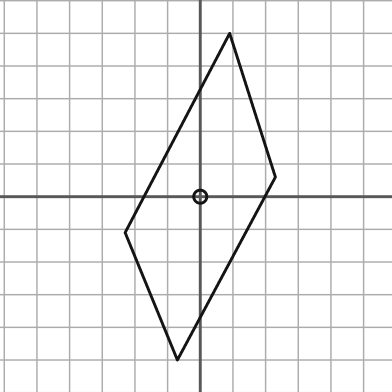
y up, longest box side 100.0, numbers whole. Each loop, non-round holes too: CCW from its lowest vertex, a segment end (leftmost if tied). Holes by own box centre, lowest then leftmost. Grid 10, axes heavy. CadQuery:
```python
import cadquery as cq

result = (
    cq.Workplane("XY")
    .moveTo(-7.0, -50.0)
    .lineTo(23.0, 6.0)
    .lineTo(9.0, 50.0)
    .lineTo(-23.0, -11.0)
    .close()
    .moveTo(0.0, 0.0)
    .circle(2.0)
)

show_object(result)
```